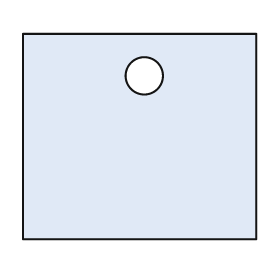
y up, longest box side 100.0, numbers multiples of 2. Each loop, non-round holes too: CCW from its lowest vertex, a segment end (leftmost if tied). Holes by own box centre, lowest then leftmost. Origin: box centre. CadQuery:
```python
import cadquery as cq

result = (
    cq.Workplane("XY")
    .moveTo(-50.0, -44.0)
    .lineTo(50.0, -44.0)
    .lineTo(50.0, 44.0)
    .lineTo(-50.0, 44.0)
    .close()
    .moveTo(2.0, 26.0)
    .circle(8.0)
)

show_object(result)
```